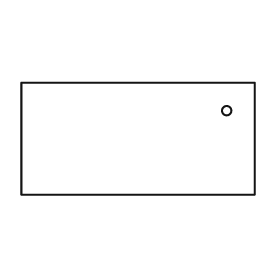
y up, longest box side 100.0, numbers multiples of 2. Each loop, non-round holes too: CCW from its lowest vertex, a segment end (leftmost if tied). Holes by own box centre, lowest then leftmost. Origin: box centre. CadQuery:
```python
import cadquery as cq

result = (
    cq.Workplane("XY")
    .moveTo(-50.0, -24.0)
    .lineTo(50.0, -24.0)
    .lineTo(50.0, 24.0)
    .lineTo(-50.0, 24.0)
    .close()
    .moveTo(38.0, 12.0)
    .circle(2.0)
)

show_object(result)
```